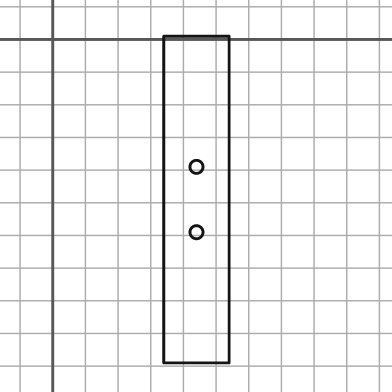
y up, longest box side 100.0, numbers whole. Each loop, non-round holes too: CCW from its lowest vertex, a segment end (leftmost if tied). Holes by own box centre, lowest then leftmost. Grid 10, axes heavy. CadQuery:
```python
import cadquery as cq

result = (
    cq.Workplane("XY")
    .moveTo(34.0, -99.0)
    .lineTo(54.0, -99.0)
    .lineTo(54.0, 1.0)
    .lineTo(34.0, 1.0)
    .close()
    .moveTo(44.0, -59.0)
    .circle(2.0)
    .moveTo(44.0, -39.0)
    .circle(2.0)
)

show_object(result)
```